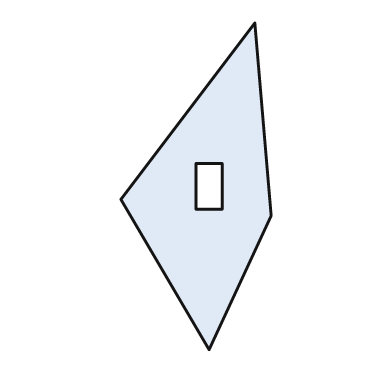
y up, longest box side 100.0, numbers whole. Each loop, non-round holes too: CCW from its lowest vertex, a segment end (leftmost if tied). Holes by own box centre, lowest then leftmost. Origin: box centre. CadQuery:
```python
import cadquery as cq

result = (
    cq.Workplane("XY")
    .moveTo(4.0, -50.0)
    .lineTo(23.0, -9.0)
    .lineTo(18.0, 50.0)
    .lineTo(-23.0, -4.0)
    .close()
    .moveTo(0.0, -7.0)
    .lineTo(8.0, -7.0)
    .lineTo(8.0, 7.0)
    .lineTo(0.0, 7.0)
    .close()
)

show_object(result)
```